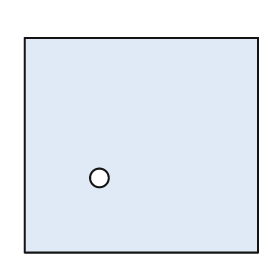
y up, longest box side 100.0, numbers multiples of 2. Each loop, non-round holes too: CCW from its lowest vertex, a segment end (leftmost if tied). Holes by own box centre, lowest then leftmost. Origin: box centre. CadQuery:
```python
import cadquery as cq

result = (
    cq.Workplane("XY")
    .moveTo(-50.0, -46.0)
    .lineTo(50.0, -46.0)
    .lineTo(50.0, 46.0)
    .lineTo(-50.0, 46.0)
    .close()
    .moveTo(-18.0, -14.0)
    .circle(4.0)
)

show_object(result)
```